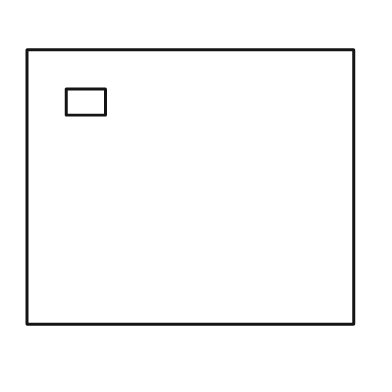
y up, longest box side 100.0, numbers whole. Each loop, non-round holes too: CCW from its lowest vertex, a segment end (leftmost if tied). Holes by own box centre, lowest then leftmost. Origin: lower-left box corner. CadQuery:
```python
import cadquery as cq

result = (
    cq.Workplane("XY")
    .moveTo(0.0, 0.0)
    .lineTo(100.0, 0.0)
    .lineTo(100.0, 84.0)
    .lineTo(0.0, 84.0)
    .close()
    .moveTo(12.0, 64.0)
    .lineTo(24.0, 64.0)
    .lineTo(24.0, 72.0)
    .lineTo(12.0, 72.0)
    .close()
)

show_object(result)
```